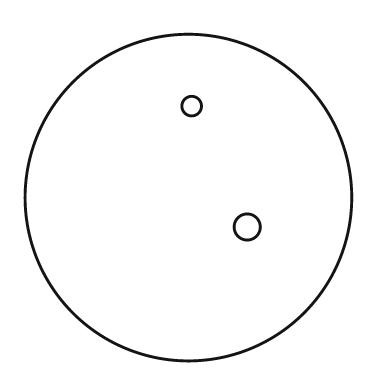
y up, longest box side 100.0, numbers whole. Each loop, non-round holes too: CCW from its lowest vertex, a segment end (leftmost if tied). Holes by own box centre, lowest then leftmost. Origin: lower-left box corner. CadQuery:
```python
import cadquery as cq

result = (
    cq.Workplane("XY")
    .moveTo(50.0, 50.0)
    .circle(50.0)
    .moveTo(68.0, 41.0)
    .circle(4.0)
    .moveTo(51.0, 78.0)
    .circle(3.0)
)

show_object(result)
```